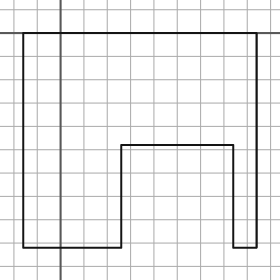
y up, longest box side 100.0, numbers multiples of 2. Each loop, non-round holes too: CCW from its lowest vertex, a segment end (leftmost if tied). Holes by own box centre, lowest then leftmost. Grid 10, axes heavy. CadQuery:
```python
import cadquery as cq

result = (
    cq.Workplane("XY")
    .moveTo(-16.0, -92.0)
    .lineTo(26.0, -92.0)
    .lineTo(26.0, -48.0)
    .lineTo(74.0, -48.0)
    .lineTo(74.0, -92.0)
    .lineTo(84.0, -92.0)
    .lineTo(84.0, 0.0)
    .lineTo(-16.0, 0.0)
    .close()
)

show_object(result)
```